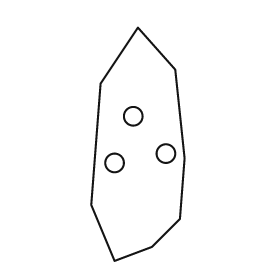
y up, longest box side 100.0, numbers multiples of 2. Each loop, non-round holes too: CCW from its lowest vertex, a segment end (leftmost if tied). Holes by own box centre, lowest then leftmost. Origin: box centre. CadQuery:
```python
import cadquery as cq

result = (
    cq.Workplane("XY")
    .moveTo(-10.0, -50.0)
    .lineTo(6.0, -44.0)
    .lineTo(18.0, -32.0)
    .lineTo(20.0, -6.0)
    .lineTo(16.0, 32.0)
    .lineTo(0.0, 50.0)
    .lineTo(-16.0, 26.0)
    .lineTo(-20.0, -26.0)
    .close()
    .moveTo(-10.0, -8.0)
    .circle(4.0)
    .moveTo(12.0, -4.0)
    .circle(4.0)
    .moveTo(-2.0, 12.0)
    .circle(4.0)
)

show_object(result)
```